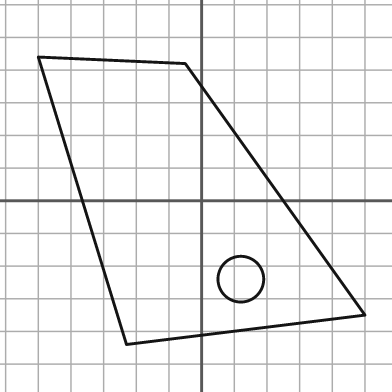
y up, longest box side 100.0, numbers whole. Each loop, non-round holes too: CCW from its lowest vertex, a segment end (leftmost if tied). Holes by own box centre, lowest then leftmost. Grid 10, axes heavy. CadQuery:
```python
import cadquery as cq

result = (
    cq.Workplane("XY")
    .moveTo(-23.0, -44.0)
    .lineTo(50.0, -35.0)
    .lineTo(-5.0, 42.0)
    .lineTo(-50.0, 44.0)
    .close()
    .moveTo(12.0, -24.0)
    .circle(7.0)
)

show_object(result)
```